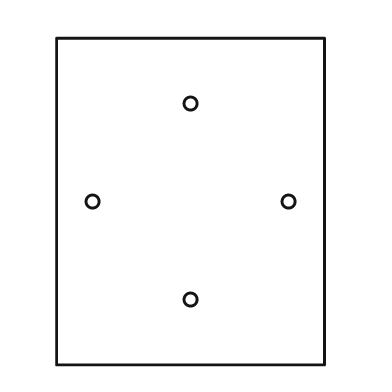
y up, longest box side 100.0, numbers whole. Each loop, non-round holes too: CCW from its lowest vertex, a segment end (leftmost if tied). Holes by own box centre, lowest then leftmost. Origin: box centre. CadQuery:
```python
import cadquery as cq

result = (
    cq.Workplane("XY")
    .moveTo(-41.0, -50.0)
    .lineTo(41.0, -50.0)
    .lineTo(41.0, 50.0)
    .lineTo(-41.0, 50.0)
    .close()
    .moveTo(0.0, -30.0)
    .circle(2.0)
    .moveTo(-30.0, 0.0)
    .circle(2.0)
    .moveTo(30.0, 0.0)
    .circle(2.0)
    .moveTo(0.0, 30.0)
    .circle(2.0)
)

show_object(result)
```